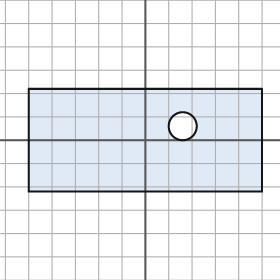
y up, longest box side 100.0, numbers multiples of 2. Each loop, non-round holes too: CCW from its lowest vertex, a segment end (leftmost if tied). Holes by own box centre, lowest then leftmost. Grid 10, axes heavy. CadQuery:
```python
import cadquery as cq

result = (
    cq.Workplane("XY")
    .moveTo(-50.0, -22.0)
    .lineTo(50.0, -22.0)
    .lineTo(50.0, 22.0)
    .lineTo(-50.0, 22.0)
    .close()
    .moveTo(16.0, 6.0)
    .circle(6.0)
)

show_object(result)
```